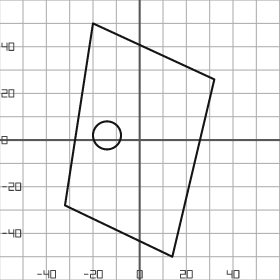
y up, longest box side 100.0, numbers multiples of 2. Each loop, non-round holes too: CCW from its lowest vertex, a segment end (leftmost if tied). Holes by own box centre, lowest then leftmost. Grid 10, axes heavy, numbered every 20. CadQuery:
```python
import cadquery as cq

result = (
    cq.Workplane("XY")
    .moveTo(14.0, -50.0)
    .lineTo(32.0, 26.0)
    .lineTo(-20.0, 50.0)
    .lineTo(-32.0, -28.0)
    .close()
    .moveTo(-14.0, 2.0)
    .circle(6.0)
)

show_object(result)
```